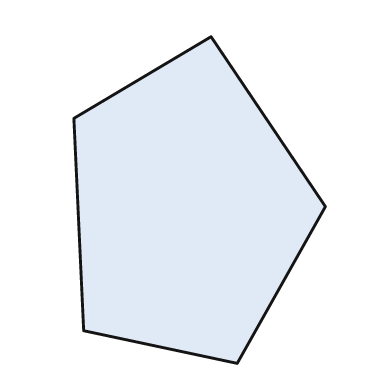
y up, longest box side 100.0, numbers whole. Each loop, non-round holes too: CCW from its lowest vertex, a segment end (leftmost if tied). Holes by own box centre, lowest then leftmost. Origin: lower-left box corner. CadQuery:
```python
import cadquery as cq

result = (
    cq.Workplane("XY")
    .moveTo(50.0, 0.0)
    .lineTo(77.0, 48.0)
    .lineTo(42.0, 100.0)
    .lineTo(0.0, 75.0)
    .lineTo(3.0, 10.0)
    .close()
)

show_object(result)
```